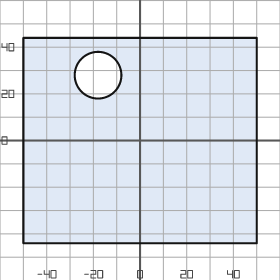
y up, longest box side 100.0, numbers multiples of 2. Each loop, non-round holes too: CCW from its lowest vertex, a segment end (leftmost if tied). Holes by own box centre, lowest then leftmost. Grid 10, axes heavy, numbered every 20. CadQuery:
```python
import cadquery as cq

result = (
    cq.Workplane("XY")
    .moveTo(-50.0, -44.0)
    .lineTo(50.0, -44.0)
    .lineTo(50.0, 44.0)
    .lineTo(-50.0, 44.0)
    .close()
    .moveTo(-18.0, 28.0)
    .circle(10.0)
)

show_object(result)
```